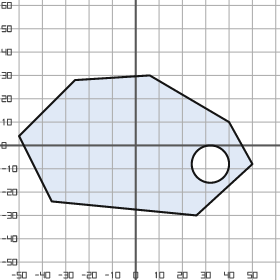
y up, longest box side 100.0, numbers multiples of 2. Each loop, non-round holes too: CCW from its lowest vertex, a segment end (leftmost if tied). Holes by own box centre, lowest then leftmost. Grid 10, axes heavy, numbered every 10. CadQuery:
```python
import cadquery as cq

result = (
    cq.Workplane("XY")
    .moveTo(26.0, -30.0)
    .lineTo(50.0, -8.0)
    .lineTo(40.0, 10.0)
    .lineTo(6.0, 30.0)
    .lineTo(-26.0, 28.0)
    .lineTo(-50.0, 4.0)
    .lineTo(-36.0, -24.0)
    .close()
    .moveTo(32.0, -8.0)
    .circle(8.0)
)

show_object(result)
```